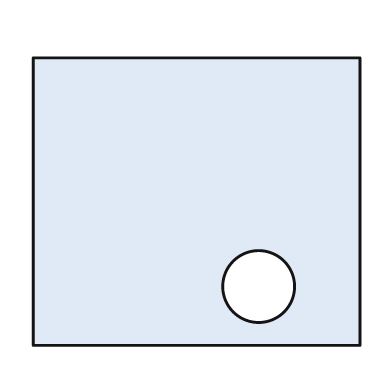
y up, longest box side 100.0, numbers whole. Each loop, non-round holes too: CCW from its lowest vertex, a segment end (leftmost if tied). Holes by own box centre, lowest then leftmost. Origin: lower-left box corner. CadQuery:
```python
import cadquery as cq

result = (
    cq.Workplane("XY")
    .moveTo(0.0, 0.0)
    .lineTo(100.0, 0.0)
    .lineTo(100.0, 88.0)
    .lineTo(0.0, 88.0)
    .close()
    .moveTo(69.0, 18.0)
    .circle(11.0)
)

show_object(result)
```